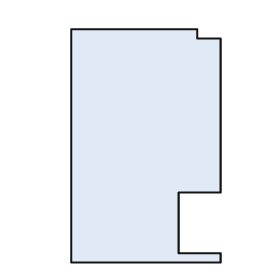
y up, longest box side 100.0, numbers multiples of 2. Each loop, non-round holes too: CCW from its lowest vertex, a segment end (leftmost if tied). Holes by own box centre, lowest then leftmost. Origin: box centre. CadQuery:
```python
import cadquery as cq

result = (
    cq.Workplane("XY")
    .moveTo(-32.0, -50.0)
    .lineTo(32.0, -50.0)
    .lineTo(32.0, -46.0)
    .lineTo(14.0, -46.0)
    .lineTo(14.0, -20.0)
    .lineTo(32.0, -20.0)
    .lineTo(32.0, 46.0)
    .lineTo(22.0, 46.0)
    .lineTo(22.0, 50.0)
    .lineTo(-32.0, 50.0)
    .close()
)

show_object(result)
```